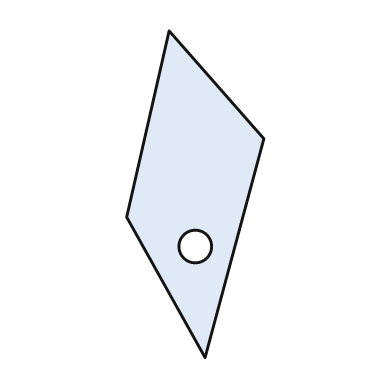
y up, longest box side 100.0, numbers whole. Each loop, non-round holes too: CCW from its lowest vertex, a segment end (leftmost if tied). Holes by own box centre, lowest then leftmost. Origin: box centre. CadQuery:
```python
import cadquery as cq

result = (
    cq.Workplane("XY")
    .moveTo(3.0, -50.0)
    .lineTo(21.0, 17.0)
    .lineTo(-8.0, 50.0)
    .lineTo(-21.0, -7.0)
    .close()
    .moveTo(0.0, -16.0)
    .circle(5.0)
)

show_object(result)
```